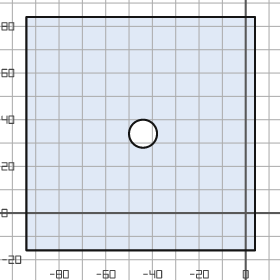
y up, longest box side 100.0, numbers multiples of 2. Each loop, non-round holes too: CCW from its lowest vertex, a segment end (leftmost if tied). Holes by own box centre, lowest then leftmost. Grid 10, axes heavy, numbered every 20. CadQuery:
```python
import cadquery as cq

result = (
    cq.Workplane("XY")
    .moveTo(-94.0, -16.0)
    .lineTo(4.0, -16.0)
    .lineTo(4.0, 84.0)
    .lineTo(-94.0, 84.0)
    .close()
    .moveTo(-44.0, 34.0)
    .circle(6.0)
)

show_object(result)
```